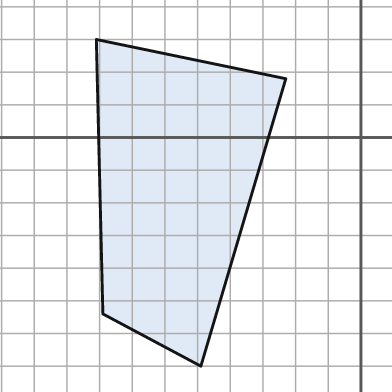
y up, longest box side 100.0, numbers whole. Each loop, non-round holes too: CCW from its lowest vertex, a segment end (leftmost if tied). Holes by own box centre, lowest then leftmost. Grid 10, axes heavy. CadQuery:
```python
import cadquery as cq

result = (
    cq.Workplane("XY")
    .moveTo(-49.0, -70.0)
    .lineTo(-23.0, 18.0)
    .lineTo(-81.0, 30.0)
    .lineTo(-79.0, -54.0)
    .close()
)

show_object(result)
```